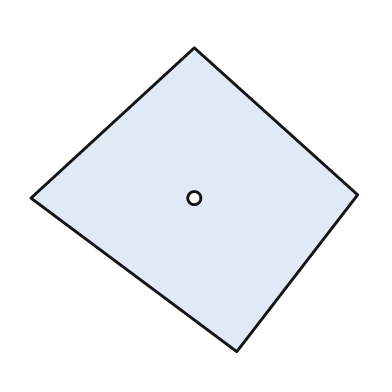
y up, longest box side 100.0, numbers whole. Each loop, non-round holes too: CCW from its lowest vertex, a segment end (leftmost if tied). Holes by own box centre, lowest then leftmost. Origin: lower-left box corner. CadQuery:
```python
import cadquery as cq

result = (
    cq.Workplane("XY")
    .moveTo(63.0, 0.0)
    .lineTo(100.0, 48.0)
    .lineTo(50.0, 93.0)
    .lineTo(0.0, 47.0)
    .close()
    .moveTo(50.0, 47.0)
    .circle(2.0)
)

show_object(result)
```